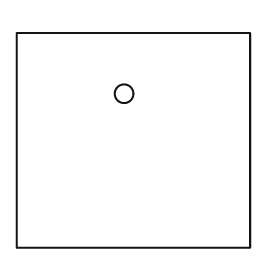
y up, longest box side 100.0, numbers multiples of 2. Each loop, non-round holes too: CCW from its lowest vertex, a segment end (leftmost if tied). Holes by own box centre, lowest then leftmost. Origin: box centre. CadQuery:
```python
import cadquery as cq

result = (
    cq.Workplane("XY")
    .moveTo(-50.0, -46.0)
    .lineTo(50.0, -46.0)
    .lineTo(50.0, 46.0)
    .lineTo(-50.0, 46.0)
    .close()
    .moveTo(-4.0, 20.0)
    .circle(4.0)
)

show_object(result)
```